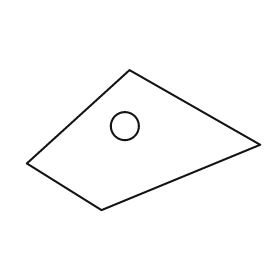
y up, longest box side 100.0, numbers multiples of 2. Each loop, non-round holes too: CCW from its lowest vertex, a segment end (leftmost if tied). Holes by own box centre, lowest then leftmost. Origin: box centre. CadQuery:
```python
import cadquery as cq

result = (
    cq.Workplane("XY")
    .moveTo(-18.0, -30.0)
    .lineTo(50.0, -2.0)
    .lineTo(-6.0, 30.0)
    .lineTo(-50.0, -10.0)
    .close()
    .moveTo(-8.0, 6.0)
    .circle(6.0)
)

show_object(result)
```